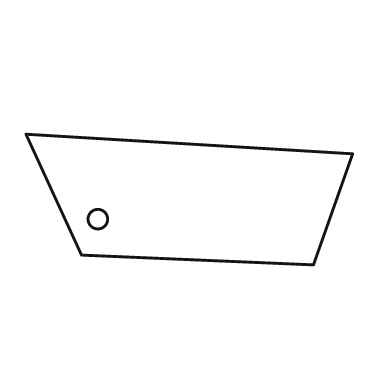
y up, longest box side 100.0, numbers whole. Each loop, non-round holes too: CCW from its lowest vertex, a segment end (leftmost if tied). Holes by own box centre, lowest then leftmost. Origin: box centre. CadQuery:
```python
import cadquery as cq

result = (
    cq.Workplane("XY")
    .moveTo(38.0, -20.0)
    .lineTo(50.0, 14.0)
    .lineTo(-50.0, 20.0)
    .lineTo(-33.0, -17.0)
    .close()
    .moveTo(-28.0, -6.0)
    .circle(3.0)
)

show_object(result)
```